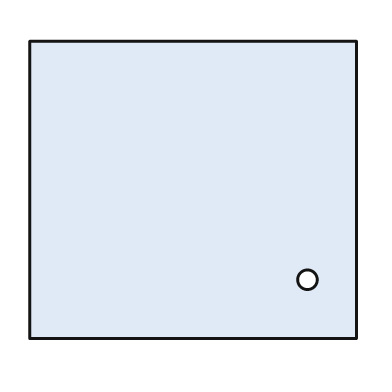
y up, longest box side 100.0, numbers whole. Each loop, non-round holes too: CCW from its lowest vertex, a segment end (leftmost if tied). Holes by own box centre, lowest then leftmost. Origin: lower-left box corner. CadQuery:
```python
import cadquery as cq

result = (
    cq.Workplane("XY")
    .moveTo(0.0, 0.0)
    .lineTo(100.0, 0.0)
    .lineTo(100.0, 91.0)
    .lineTo(0.0, 91.0)
    .close()
    .moveTo(85.0, 18.0)
    .circle(3.0)
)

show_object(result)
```